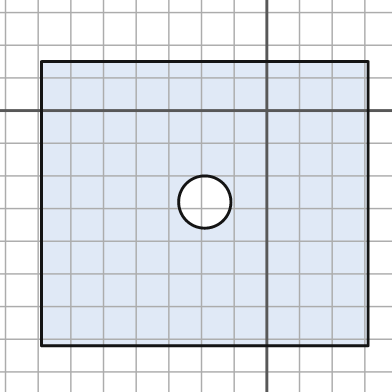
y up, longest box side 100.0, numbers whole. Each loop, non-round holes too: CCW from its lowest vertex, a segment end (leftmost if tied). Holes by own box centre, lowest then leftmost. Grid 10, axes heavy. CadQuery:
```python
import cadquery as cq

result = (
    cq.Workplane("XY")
    .moveTo(-69.0, -72.0)
    .lineTo(31.0, -72.0)
    .lineTo(31.0, 15.0)
    .lineTo(-69.0, 15.0)
    .close()
    .moveTo(-19.0, -28.0)
    .circle(8.0)
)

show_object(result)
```